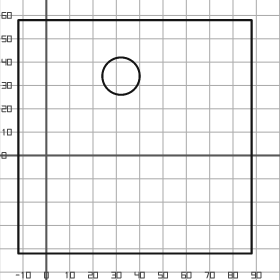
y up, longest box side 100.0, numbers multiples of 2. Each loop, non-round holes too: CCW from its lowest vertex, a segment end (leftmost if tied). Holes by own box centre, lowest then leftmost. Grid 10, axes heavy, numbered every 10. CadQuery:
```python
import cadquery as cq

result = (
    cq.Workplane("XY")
    .moveTo(-12.0, -42.0)
    .lineTo(88.0, -42.0)
    .lineTo(88.0, 58.0)
    .lineTo(-12.0, 58.0)
    .close()
    .moveTo(32.0, 34.0)
    .circle(8.0)
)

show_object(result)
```